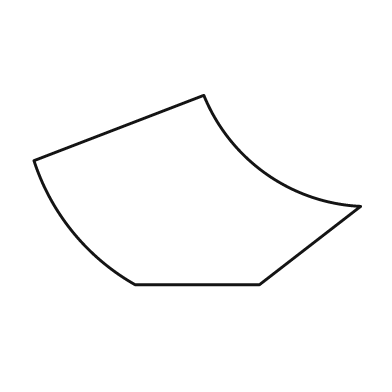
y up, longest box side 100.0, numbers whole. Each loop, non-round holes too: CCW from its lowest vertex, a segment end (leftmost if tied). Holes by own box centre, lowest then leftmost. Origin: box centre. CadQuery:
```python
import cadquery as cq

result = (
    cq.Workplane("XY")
    .moveTo(-19.0, -29.0)
    .lineTo(19.0, -29.0)
    .lineTo(50.0, -5.0)
    .threePointArc((21.0, 5.0), (2.0, 29.0))
    .lineTo(-50.0, 9.0)
    .threePointArc((-38.0, -13.0), (-19.0, -29.0))
    .close()
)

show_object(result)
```